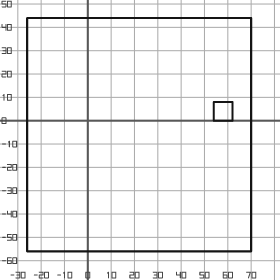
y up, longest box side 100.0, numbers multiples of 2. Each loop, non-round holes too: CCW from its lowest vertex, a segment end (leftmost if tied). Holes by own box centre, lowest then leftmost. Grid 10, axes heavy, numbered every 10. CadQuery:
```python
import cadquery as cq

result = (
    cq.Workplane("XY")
    .moveTo(-26.0, -56.0)
    .lineTo(70.0, -56.0)
    .lineTo(70.0, 44.0)
    .lineTo(-26.0, 44.0)
    .close()
    .moveTo(54.0, 0.0)
    .lineTo(62.0, 0.0)
    .lineTo(62.0, 8.0)
    .lineTo(54.0, 8.0)
    .close()
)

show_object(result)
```